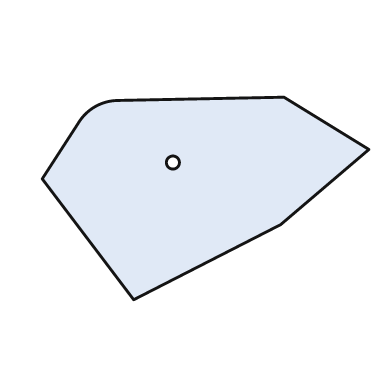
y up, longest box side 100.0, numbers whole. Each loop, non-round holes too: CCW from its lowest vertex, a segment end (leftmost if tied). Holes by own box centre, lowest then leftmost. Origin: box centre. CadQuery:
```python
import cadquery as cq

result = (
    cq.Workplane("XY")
    .moveTo(-22.0, -31.0)
    .lineTo(23.0, -8.0)
    .lineTo(50.0, 15.0)
    .lineTo(24.0, 31.0)
    .lineTo(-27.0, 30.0)
    .threePointArc((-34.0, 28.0), (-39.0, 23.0))
    .lineTo(-50.0, 6.0)
    .close()
    .moveTo(-10.0, 11.0)
    .circle(2.0)
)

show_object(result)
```